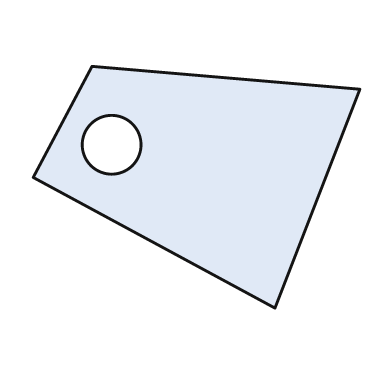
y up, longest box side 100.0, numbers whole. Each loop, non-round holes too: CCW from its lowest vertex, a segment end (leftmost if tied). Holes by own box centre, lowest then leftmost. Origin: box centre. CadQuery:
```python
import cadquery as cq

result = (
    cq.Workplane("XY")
    .moveTo(24.0, -37.0)
    .lineTo(50.0, 30.0)
    .lineTo(-32.0, 37.0)
    .lineTo(-50.0, 3.0)
    .close()
    .moveTo(-26.0, 13.0)
    .circle(9.0)
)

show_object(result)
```